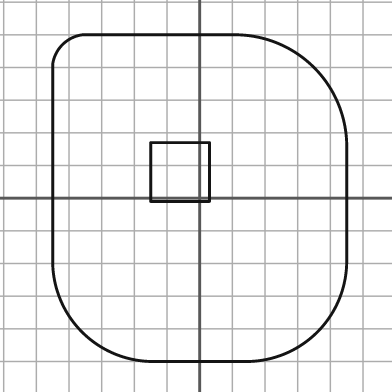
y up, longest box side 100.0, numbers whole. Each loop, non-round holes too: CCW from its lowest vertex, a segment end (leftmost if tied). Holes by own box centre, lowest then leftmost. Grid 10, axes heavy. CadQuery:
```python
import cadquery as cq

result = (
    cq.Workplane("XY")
    .moveTo(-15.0, -50.0)
    .lineTo(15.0, -50.0)
    .threePointArc((36.0, -41.0), (45.0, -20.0))
    .lineTo(45.0, 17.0)
    .threePointArc((35.0, 40.0), (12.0, 50.0))
    .lineTo(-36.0, 50.0)
    .threePointArc((-42.0, 47.0), (-45.0, 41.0))
    .lineTo(-45.0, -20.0)
    .threePointArc((-36.0, -41.0), (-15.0, -50.0))
    .close()
    .moveTo(-15.0, -1.0)
    .lineTo(3.0, -1.0)
    .lineTo(3.0, 17.0)
    .lineTo(-15.0, 17.0)
    .close()
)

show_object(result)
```